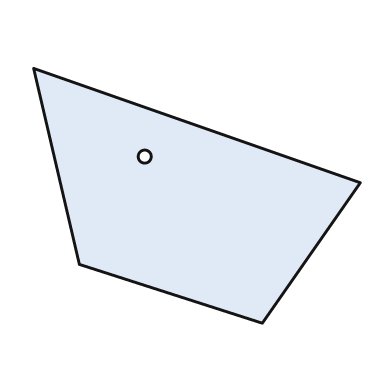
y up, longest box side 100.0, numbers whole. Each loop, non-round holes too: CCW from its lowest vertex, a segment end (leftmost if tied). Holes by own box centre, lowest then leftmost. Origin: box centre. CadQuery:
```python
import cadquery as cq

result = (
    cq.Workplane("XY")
    .moveTo(20.0, -39.0)
    .lineTo(50.0, 4.0)
    .lineTo(-50.0, 39.0)
    .lineTo(-36.0, -21.0)
    .close()
    .moveTo(-16.0, 12.0)
    .circle(2.0)
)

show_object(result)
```